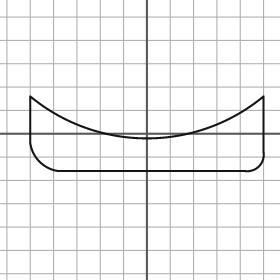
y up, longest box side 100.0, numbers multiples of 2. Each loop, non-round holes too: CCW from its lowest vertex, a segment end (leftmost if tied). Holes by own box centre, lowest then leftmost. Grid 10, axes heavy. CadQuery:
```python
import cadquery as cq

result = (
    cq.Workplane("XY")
    .moveTo(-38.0, -16.0)
    .lineTo(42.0, -16.0)
    .threePointArc((48.0, -14.0), (50.0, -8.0))
    .lineTo(50.0, 16.0)
    .threePointArc((0.0, -2.0), (-50.0, 16.0))
    .lineTo(-50.0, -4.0)
    .threePointArc((-46.0, -12.0), (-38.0, -16.0))
    .close()
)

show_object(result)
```